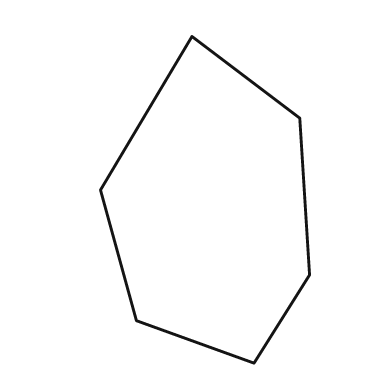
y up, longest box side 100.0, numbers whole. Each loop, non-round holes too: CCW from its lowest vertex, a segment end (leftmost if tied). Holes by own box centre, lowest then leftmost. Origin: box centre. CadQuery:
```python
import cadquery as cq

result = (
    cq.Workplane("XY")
    .moveTo(15.0, -50.0)
    .lineTo(32.0, -23.0)
    .lineTo(29.0, 25.0)
    .lineTo(-4.0, 50.0)
    .lineTo(-32.0, 3.0)
    .lineTo(-21.0, -37.0)
    .close()
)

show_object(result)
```